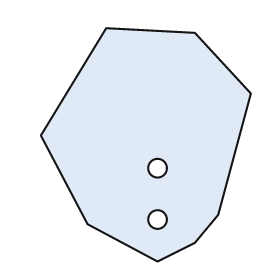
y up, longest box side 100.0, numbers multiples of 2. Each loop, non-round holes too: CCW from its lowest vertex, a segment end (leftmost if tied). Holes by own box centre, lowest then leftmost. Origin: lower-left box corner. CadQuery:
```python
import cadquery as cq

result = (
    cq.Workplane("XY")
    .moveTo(50.0, 0.0)
    .lineTo(66.0, 8.0)
    .lineTo(76.0, 20.0)
    .lineTo(90.0, 72.0)
    .lineTo(66.0, 98.0)
    .lineTo(28.0, 100.0)
    .lineTo(0.0, 54.0)
    .lineTo(20.0, 16.0)
    .close()
    .moveTo(50.0, 18.0)
    .circle(4.0)
    .moveTo(50.0, 40.0)
    .circle(4.0)
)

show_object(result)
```